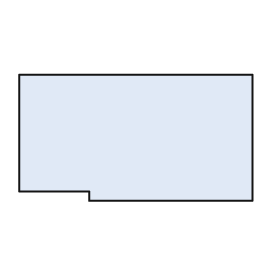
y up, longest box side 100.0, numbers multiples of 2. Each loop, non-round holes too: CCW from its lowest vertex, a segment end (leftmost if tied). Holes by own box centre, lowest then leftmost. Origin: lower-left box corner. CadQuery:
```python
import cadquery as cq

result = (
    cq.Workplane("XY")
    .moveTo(30.0, 0.0)
    .lineTo(100.0, 0.0)
    .lineTo(100.0, 54.0)
    .lineTo(0.0, 54.0)
    .lineTo(0.0, 4.0)
    .lineTo(30.0, 4.0)
    .close()
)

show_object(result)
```